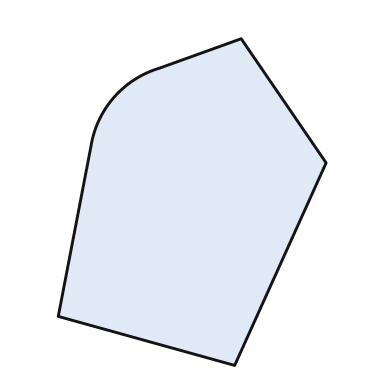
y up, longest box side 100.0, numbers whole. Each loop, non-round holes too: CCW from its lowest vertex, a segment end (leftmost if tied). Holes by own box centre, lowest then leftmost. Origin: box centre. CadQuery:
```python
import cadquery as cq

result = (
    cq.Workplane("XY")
    .moveTo(13.0, -50.0)
    .lineTo(41.0, 12.0)
    .lineTo(15.0, 50.0)
    .lineTo(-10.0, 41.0)
    .threePointArc((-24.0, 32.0), (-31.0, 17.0))
    .lineTo(-41.0, -35.0)
    .close()
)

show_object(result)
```